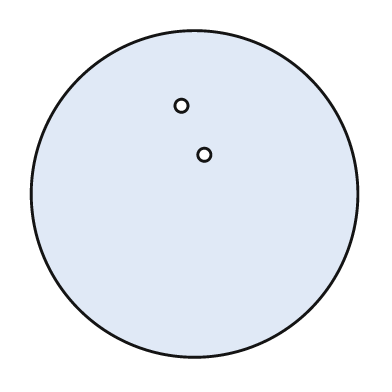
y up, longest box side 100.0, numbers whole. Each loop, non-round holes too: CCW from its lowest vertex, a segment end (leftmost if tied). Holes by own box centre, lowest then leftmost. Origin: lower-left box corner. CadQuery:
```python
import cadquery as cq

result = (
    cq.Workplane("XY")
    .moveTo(50.0, 50.0)
    .circle(50.0)
    .moveTo(53.0, 62.0)
    .circle(2.0)
    .moveTo(46.0, 77.0)
    .circle(2.0)
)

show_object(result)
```